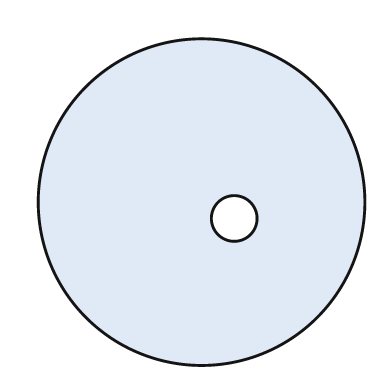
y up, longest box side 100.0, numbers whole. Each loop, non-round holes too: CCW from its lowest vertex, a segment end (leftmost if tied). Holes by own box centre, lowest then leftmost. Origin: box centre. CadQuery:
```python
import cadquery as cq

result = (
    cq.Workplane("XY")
    .moveTo(0.0, 0.0)
    .circle(50.0)
    .moveTo(10.0, -5.0)
    .circle(7.0)
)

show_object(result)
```